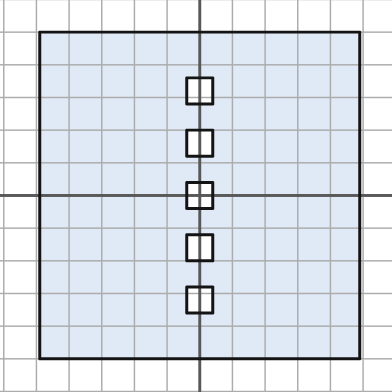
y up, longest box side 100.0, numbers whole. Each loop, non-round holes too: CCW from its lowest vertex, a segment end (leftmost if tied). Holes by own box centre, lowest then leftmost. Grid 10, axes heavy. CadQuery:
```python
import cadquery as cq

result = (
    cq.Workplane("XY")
    .moveTo(-49.0, -50.0)
    .lineTo(49.0, -50.0)
    .lineTo(49.0, 50.0)
    .lineTo(-49.0, 50.0)
    .close()
    .moveTo(-4.0, -36.0)
    .lineTo(4.0, -36.0)
    .lineTo(4.0, -28.0)
    .lineTo(-4.0, -28.0)
    .close()
    .moveTo(-4.0, -20.0)
    .lineTo(4.0, -20.0)
    .lineTo(4.0, -12.0)
    .lineTo(-4.0, -12.0)
    .close()
    .moveTo(-4.0, -4.0)
    .lineTo(4.0, -4.0)
    .lineTo(4.0, 4.0)
    .lineTo(-4.0, 4.0)
    .close()
    .moveTo(-4.0, 12.0)
    .lineTo(4.0, 12.0)
    .lineTo(4.0, 20.0)
    .lineTo(-4.0, 20.0)
    .close()
    .moveTo(-4.0, 28.0)
    .lineTo(4.0, 28.0)
    .lineTo(4.0, 36.0)
    .lineTo(-4.0, 36.0)
    .close()
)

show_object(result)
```